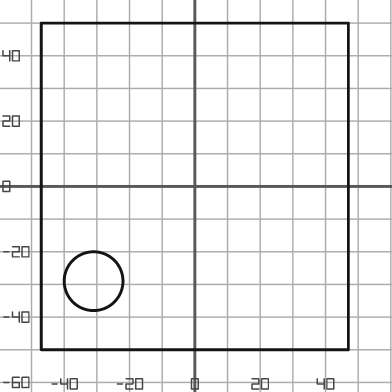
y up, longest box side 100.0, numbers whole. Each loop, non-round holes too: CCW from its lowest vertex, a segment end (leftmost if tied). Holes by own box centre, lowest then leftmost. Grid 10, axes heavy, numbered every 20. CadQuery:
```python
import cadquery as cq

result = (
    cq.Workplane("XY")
    .moveTo(-47.0, -50.0)
    .lineTo(47.0, -50.0)
    .lineTo(47.0, 50.0)
    .lineTo(-47.0, 50.0)
    .close()
    .moveTo(-31.0, -29.0)
    .circle(9.0)
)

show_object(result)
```